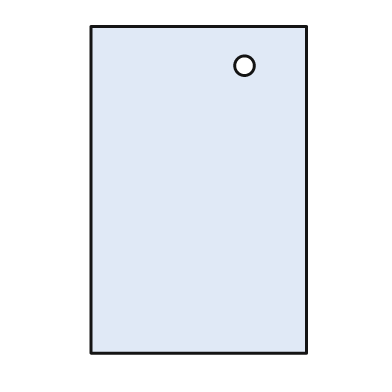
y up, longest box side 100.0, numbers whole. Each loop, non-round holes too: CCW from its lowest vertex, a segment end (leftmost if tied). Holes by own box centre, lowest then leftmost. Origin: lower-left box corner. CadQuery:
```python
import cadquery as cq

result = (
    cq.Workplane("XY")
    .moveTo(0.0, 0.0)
    .lineTo(66.0, 0.0)
    .lineTo(66.0, 100.0)
    .lineTo(0.0, 100.0)
    .close()
    .moveTo(47.0, 88.0)
    .circle(3.0)
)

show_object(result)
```